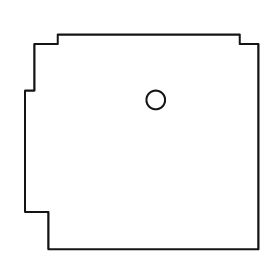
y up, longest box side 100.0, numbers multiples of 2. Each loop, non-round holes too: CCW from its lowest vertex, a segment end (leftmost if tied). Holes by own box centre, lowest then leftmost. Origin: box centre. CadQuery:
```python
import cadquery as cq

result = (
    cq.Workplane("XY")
    .moveTo(-40.0, -46.0)
    .lineTo(50.0, -46.0)
    .lineTo(50.0, 42.0)
    .lineTo(42.0, 42.0)
    .lineTo(42.0, 46.0)
    .lineTo(-36.0, 46.0)
    .lineTo(-36.0, 42.0)
    .lineTo(-46.0, 42.0)
    .lineTo(-46.0, 22.0)
    .lineTo(-50.0, 22.0)
    .lineTo(-50.0, -30.0)
    .lineTo(-40.0, -30.0)
    .close()
    .moveTo(6.0, 18.0)
    .circle(4.0)
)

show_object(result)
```